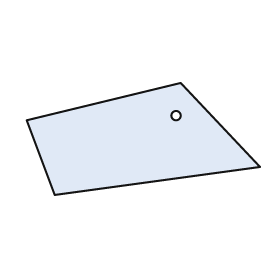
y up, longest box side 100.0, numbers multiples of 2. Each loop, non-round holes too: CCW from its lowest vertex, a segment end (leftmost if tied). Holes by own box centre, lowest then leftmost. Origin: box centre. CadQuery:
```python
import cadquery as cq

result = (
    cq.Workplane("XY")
    .moveTo(-38.0, -24.0)
    .lineTo(50.0, -12.0)
    .lineTo(16.0, 24.0)
    .lineTo(-50.0, 8.0)
    .close()
    .moveTo(14.0, 10.0)
    .circle(2.0)
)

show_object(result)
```